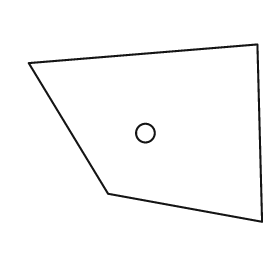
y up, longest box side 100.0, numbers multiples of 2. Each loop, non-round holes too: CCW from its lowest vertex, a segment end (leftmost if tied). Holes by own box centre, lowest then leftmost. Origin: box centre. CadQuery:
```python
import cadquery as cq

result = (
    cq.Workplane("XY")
    .moveTo(50.0, -38.0)
    .lineTo(48.0, 38.0)
    .lineTo(-50.0, 30.0)
    .lineTo(-16.0, -26.0)
    .close()
    .moveTo(0.0, 0.0)
    .circle(4.0)
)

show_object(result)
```